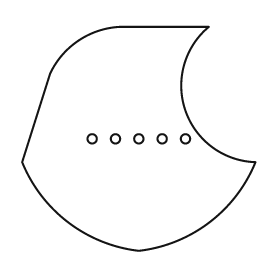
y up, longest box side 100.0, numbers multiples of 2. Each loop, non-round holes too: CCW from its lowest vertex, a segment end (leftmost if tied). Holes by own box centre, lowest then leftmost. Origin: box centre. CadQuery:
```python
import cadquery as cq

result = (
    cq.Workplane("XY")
    .moveTo(0.0, -48.0)
    .threePointArc((30.0, -36.0), (50.0, -10.0))
    .threePointArc((20.0, 12.0), (30.0, 48.0))
    .lineTo(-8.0, 48.0)
    .threePointArc((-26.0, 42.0), (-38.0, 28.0))
    .lineTo(-50.0, -10.0)
    .threePointArc((-30.0, -36.0), (0.0, -48.0))
    .close()
    .moveTo(-20.0, 0.0)
    .circle(2.0)
    .moveTo(-10.0, 0.0)
    .circle(2.0)
    .moveTo(0.0, 0.0)
    .circle(2.0)
    .moveTo(10.0, 0.0)
    .circle(2.0)
    .moveTo(20.0, 0.0)
    .circle(2.0)
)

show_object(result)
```